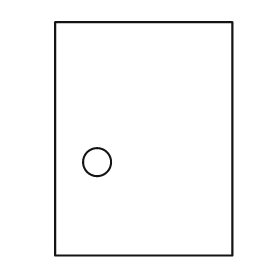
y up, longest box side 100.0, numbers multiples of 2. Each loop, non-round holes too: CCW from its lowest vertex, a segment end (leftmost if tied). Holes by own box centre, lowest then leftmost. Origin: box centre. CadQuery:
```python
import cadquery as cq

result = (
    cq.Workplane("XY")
    .moveTo(-38.0, -50.0)
    .lineTo(38.0, -50.0)
    .lineTo(38.0, 50.0)
    .lineTo(-38.0, 50.0)
    .close()
    .moveTo(-20.0, -10.0)
    .circle(6.0)
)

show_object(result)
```